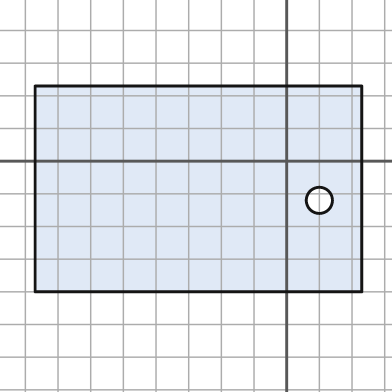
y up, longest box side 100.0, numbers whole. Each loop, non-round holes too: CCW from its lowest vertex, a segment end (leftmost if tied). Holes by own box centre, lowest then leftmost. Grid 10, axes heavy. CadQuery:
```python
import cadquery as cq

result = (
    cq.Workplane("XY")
    .moveTo(-77.0, -40.0)
    .lineTo(23.0, -40.0)
    .lineTo(23.0, 23.0)
    .lineTo(-77.0, 23.0)
    .close()
    .moveTo(10.0, -12.0)
    .circle(4.0)
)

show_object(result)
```